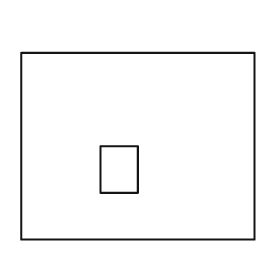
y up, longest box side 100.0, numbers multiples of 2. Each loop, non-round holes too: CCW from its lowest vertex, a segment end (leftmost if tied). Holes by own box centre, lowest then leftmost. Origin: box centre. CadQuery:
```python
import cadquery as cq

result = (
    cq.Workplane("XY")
    .moveTo(-50.0, -40.0)
    .lineTo(50.0, -40.0)
    .lineTo(50.0, 40.0)
    .lineTo(-50.0, 40.0)
    .close()
    .moveTo(-16.0, -20.0)
    .lineTo(0.0, -20.0)
    .lineTo(0.0, 0.0)
    .lineTo(-16.0, 0.0)
    .close()
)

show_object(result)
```